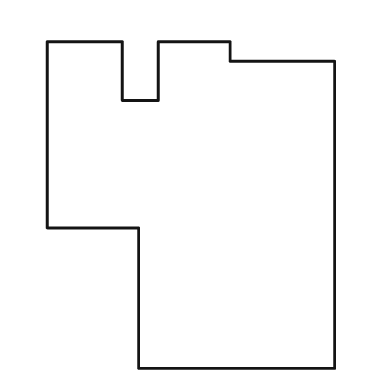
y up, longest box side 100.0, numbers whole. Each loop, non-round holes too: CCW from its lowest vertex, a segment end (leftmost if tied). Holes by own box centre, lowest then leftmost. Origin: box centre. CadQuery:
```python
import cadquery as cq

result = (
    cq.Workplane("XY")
    .moveTo(-16.0, -50.0)
    .lineTo(44.0, -50.0)
    .lineTo(44.0, 44.0)
    .lineTo(12.0, 44.0)
    .lineTo(12.0, 50.0)
    .lineTo(-10.0, 50.0)
    .lineTo(-10.0, 32.0)
    .lineTo(-21.0, 32.0)
    .lineTo(-21.0, 50.0)
    .lineTo(-44.0, 50.0)
    .lineTo(-44.0, -7.0)
    .lineTo(-16.0, -7.0)
    .close()
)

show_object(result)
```